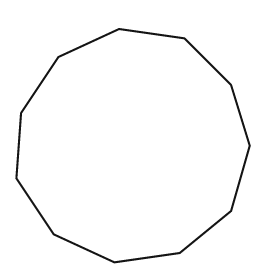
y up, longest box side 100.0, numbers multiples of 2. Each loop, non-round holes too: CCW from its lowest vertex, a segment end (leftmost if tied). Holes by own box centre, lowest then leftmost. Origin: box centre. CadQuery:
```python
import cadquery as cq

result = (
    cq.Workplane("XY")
    .moveTo(-8.0, -50.0)
    .lineTo(20.0, -46.0)
    .lineTo(42.0, -28.0)
    .lineTo(50.0, 0.0)
    .lineTo(42.0, 26.0)
    .lineTo(22.0, 46.0)
    .lineTo(-6.0, 50.0)
    .lineTo(-32.0, 38.0)
    .lineTo(-48.0, 14.0)
    .lineTo(-50.0, -14.0)
    .lineTo(-34.0, -38.0)
    .close()
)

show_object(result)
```